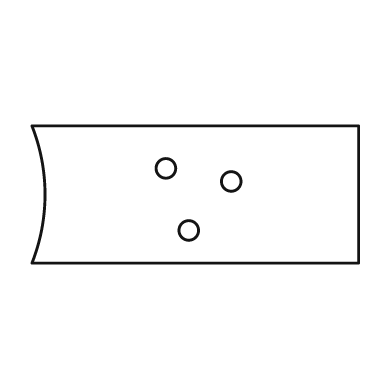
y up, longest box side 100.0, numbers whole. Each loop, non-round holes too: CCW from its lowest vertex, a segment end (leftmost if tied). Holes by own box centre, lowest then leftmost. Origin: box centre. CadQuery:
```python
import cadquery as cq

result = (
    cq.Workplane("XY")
    .moveTo(-50.0, -21.0)
    .lineTo(50.0, -21.0)
    .lineTo(50.0, 21.0)
    .lineTo(-50.0, 21.0)
    .threePointArc((-46.0, 0.0), (-50.0, -21.0))
    .close()
    .moveTo(-2.0, -11.0)
    .circle(3.0)
    .moveTo(11.0, 4.0)
    .circle(3.0)
    .moveTo(-9.0, 8.0)
    .circle(3.0)
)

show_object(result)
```